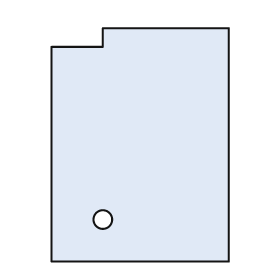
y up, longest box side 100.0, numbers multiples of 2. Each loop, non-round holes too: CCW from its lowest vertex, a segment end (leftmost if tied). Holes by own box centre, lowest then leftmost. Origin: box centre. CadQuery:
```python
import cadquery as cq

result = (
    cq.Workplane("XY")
    .moveTo(-38.0, -50.0)
    .lineTo(38.0, -50.0)
    .lineTo(38.0, 50.0)
    .lineTo(-16.0, 50.0)
    .lineTo(-16.0, 42.0)
    .lineTo(-38.0, 42.0)
    .close()
    .moveTo(-16.0, -32.0)
    .circle(4.0)
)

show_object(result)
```